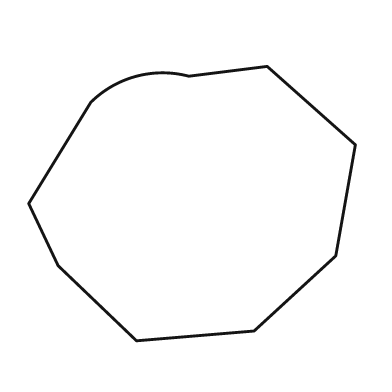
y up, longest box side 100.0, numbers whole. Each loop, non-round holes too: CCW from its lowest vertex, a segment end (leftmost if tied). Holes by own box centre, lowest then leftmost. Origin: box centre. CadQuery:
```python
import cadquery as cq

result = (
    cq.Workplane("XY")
    .moveTo(-17.0, -42.0)
    .lineTo(19.0, -39.0)
    .lineTo(44.0, -16.0)
    .lineTo(50.0, 18.0)
    .lineTo(23.0, 42.0)
    .lineTo(-1.0, 39.0)
    .threePointArc((-17.0, 39.0), (-31.0, 31.0))
    .lineTo(-50.0, 0.0)
    .lineTo(-41.0, -19.0)
    .close()
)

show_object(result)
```